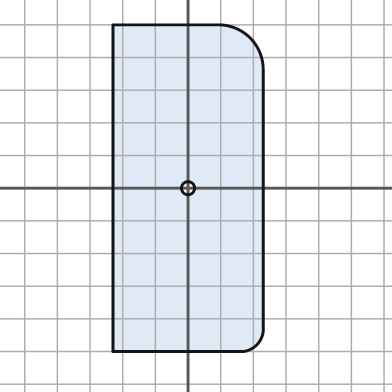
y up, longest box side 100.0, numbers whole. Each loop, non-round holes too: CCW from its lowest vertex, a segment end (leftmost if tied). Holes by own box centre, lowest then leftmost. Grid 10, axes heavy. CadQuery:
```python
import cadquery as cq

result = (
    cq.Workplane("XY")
    .moveTo(-23.0, -50.0)
    .lineTo(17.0, -50.0)
    .threePointArc((21.0, -48.0), (23.0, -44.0))
    .lineTo(23.0, 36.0)
    .threePointArc((19.0, 46.0), (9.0, 50.0))
    .lineTo(-23.0, 50.0)
    .close()
    .moveTo(0.0, 0.0)
    .circle(2.0)
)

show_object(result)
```